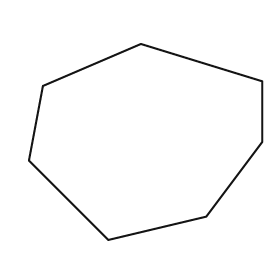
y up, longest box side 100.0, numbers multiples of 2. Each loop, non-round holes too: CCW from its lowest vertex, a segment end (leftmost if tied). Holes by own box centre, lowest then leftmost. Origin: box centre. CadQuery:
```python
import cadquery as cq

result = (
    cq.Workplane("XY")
    .moveTo(-16.0, -42.0)
    .lineTo(26.0, -32.0)
    .lineTo(50.0, 0.0)
    .lineTo(50.0, 26.0)
    .lineTo(-2.0, 42.0)
    .lineTo(-44.0, 24.0)
    .lineTo(-50.0, -8.0)
    .close()
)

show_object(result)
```